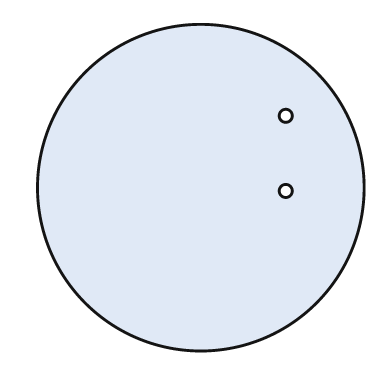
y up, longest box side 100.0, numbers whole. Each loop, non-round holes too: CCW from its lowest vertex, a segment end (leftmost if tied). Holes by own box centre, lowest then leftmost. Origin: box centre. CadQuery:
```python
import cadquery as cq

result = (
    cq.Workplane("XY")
    .moveTo(0.0, 0.0)
    .circle(50.0)
    .moveTo(26.0, -1.0)
    .circle(2.0)
    .moveTo(26.0, 22.0)
    .circle(2.0)
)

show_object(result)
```